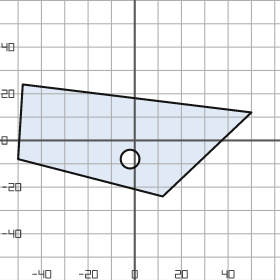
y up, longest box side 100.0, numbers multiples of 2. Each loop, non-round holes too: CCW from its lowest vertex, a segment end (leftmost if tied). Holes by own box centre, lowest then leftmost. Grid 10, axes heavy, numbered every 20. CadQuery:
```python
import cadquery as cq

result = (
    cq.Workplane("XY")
    .moveTo(12.0, -24.0)
    .lineTo(50.0, 12.0)
    .lineTo(-48.0, 24.0)
    .lineTo(-50.0, -8.0)
    .close()
    .moveTo(-2.0, -8.0)
    .circle(4.0)
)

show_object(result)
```